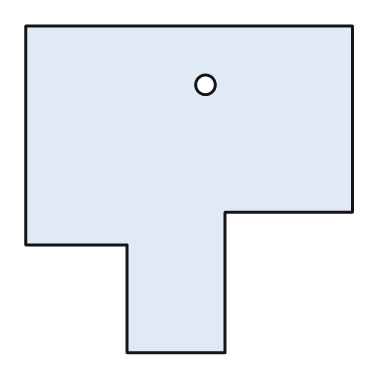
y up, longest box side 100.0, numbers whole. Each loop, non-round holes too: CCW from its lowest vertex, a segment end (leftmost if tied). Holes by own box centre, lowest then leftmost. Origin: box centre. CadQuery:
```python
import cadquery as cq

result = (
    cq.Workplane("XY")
    .moveTo(-19.0, -50.0)
    .lineTo(11.0, -50.0)
    .lineTo(11.0, -7.0)
    .lineTo(50.0, -7.0)
    .lineTo(50.0, 50.0)
    .lineTo(-50.0, 50.0)
    .lineTo(-50.0, -17.0)
    .lineTo(-19.0, -17.0)
    .close()
    .moveTo(5.0, 32.0)
    .circle(3.0)
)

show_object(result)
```